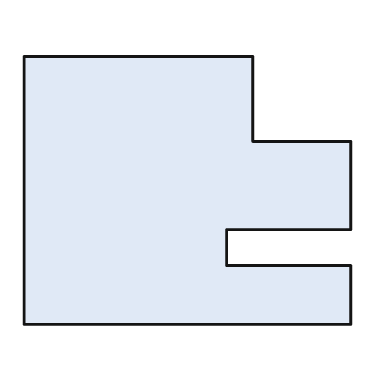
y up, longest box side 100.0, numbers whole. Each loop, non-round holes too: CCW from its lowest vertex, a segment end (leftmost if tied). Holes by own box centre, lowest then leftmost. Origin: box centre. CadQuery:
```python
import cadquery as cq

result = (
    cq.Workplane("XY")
    .moveTo(-50.0, -41.0)
    .lineTo(50.0, -41.0)
    .lineTo(50.0, -23.0)
    .lineTo(12.0, -23.0)
    .lineTo(12.0, -12.0)
    .lineTo(50.0, -12.0)
    .lineTo(50.0, 15.0)
    .lineTo(20.0, 15.0)
    .lineTo(20.0, 41.0)
    .lineTo(-50.0, 41.0)
    .close()
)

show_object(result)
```